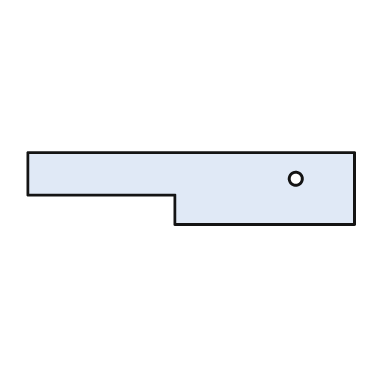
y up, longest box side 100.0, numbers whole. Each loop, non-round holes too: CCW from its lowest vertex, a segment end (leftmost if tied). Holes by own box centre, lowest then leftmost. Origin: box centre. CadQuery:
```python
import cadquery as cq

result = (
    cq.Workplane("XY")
    .moveTo(-5.0, -11.0)
    .lineTo(50.0, -11.0)
    .lineTo(50.0, 11.0)
    .lineTo(-50.0, 11.0)
    .lineTo(-50.0, -2.0)
    .lineTo(-5.0, -2.0)
    .close()
    .moveTo(32.0, 3.0)
    .circle(2.0)
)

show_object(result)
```